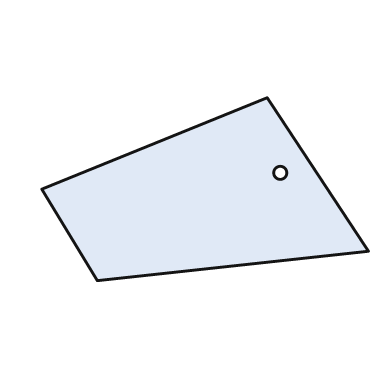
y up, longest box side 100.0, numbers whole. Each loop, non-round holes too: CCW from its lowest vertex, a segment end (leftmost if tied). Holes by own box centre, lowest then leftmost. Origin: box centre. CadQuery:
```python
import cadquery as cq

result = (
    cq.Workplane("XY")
    .moveTo(-33.0, -28.0)
    .lineTo(50.0, -19.0)
    .lineTo(19.0, 28.0)
    .lineTo(-50.0, 0.0)
    .close()
    .moveTo(23.0, 5.0)
    .circle(2.0)
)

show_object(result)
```